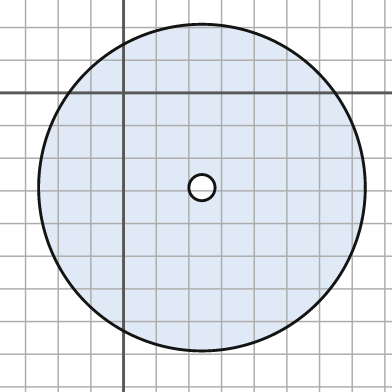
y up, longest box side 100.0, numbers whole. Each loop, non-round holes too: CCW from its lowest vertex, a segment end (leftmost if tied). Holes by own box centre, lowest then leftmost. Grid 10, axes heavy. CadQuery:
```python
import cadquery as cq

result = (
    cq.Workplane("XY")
    .moveTo(24.0, -29.0)
    .circle(50.0)
    .moveTo(24.0, -29.0)
    .circle(4.0)
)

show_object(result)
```